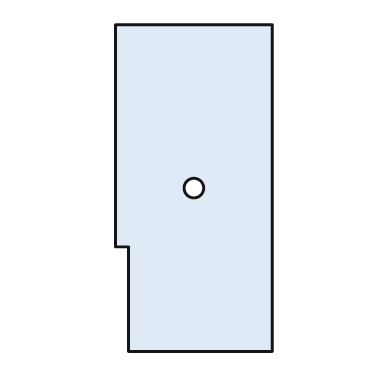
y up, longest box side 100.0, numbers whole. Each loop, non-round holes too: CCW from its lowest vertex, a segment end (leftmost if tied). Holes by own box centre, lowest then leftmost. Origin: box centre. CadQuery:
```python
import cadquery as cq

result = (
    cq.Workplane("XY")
    .moveTo(-20.0, -50.0)
    .lineTo(24.0, -50.0)
    .lineTo(24.0, 50.0)
    .lineTo(-24.0, 50.0)
    .lineTo(-24.0, -18.0)
    .lineTo(-20.0, -18.0)
    .close()
    .moveTo(0.0, 0.0)
    .circle(3.0)
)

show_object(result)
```